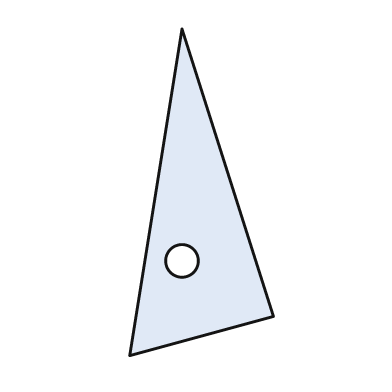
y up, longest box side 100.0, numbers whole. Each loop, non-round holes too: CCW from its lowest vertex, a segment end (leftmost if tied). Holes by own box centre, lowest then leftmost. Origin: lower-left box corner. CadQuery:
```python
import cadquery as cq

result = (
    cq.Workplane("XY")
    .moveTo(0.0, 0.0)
    .lineTo(44.0, 12.0)
    .lineTo(16.0, 100.0)
    .close()
    .moveTo(16.0, 29.0)
    .circle(5.0)
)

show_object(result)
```